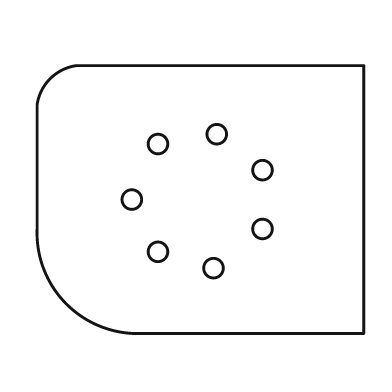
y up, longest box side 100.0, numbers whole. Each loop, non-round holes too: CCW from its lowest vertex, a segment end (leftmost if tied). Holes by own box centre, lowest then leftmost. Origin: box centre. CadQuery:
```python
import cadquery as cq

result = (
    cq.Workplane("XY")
    .moveTo(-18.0, -41.0)
    .lineTo(50.0, -41.0)
    .lineTo(50.0, 41.0)
    .lineTo(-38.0, 41.0)
    .threePointArc((-46.0, 37.0), (-50.0, 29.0))
    .lineTo(-50.0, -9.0)
    .threePointArc((-41.0, -32.0), (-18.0, -41.0))
    .close()
    .moveTo(4.0, -21.0)
    .circle(3.0)
    .moveTo(-13.0, -16.0)
    .circle(3.0)
    .moveTo(19.0, -9.0)
    .circle(3.0)
    .moveTo(-21.0, 0.0)
    .circle(3.0)
    .moveTo(19.0, 9.0)
    .circle(3.0)
    .moveTo(-13.0, 17.0)
    .circle(3.0)
    .moveTo(5.0, 20.0)
    .circle(3.0)
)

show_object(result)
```